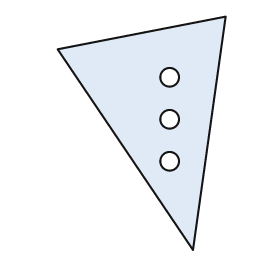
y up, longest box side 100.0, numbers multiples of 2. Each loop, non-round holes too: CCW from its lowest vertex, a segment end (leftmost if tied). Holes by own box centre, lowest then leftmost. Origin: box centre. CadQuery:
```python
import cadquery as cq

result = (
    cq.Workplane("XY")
    .moveTo(22.0, -50.0)
    .lineTo(36.0, 50.0)
    .lineTo(-36.0, 36.0)
    .close()
    .moveTo(12.0, -12.0)
    .circle(4.0)
    .moveTo(12.0, 6.0)
    .circle(4.0)
    .moveTo(12.0, 24.0)
    .circle(4.0)
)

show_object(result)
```